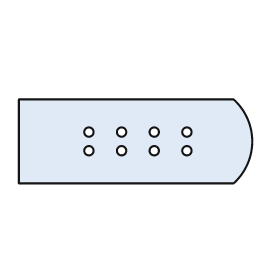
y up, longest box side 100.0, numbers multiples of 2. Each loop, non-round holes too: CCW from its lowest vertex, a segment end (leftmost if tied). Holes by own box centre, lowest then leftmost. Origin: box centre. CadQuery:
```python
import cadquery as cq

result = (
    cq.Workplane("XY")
    .moveTo(-50.0, -18.0)
    .lineTo(42.0, -18.0)
    .threePointArc((50.0, 0.0), (42.0, 18.0))
    .lineTo(-50.0, 18.0)
    .close()
    .moveTo(-20.0, -4.0)
    .circle(2.0)
    .moveTo(-6.0, -4.0)
    .circle(2.0)
    .moveTo(8.0, -4.0)
    .circle(2.0)
    .moveTo(22.0, -4.0)
    .circle(2.0)
    .moveTo(-20.0, 4.0)
    .circle(2.0)
    .moveTo(-6.0, 4.0)
    .circle(2.0)
    .moveTo(8.0, 4.0)
    .circle(2.0)
    .moveTo(22.0, 4.0)
    .circle(2.0)
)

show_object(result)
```